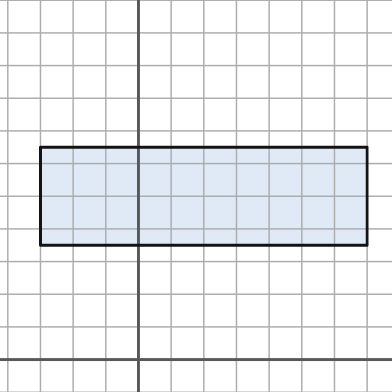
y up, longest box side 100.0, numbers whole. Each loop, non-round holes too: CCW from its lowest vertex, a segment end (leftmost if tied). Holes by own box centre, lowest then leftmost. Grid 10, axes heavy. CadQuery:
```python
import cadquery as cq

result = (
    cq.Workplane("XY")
    .moveTo(-30.0, 35.0)
    .lineTo(70.0, 35.0)
    .lineTo(70.0, 65.0)
    .lineTo(-30.0, 65.0)
    .close()
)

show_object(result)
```